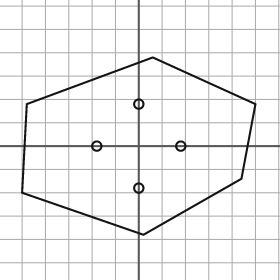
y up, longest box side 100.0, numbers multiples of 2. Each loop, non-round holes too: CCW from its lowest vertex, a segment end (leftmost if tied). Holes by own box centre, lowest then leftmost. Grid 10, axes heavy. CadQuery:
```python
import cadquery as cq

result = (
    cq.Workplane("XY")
    .moveTo(2.0, -38.0)
    .lineTo(44.0, -14.0)
    .lineTo(50.0, 18.0)
    .lineTo(6.0, 38.0)
    .lineTo(-48.0, 18.0)
    .lineTo(-50.0, -20.0)
    .close()
    .moveTo(0.0, -18.0)
    .circle(2.0)
    .moveTo(-18.0, 0.0)
    .circle(2.0)
    .moveTo(18.0, 0.0)
    .circle(2.0)
    .moveTo(0.0, 18.0)
    .circle(2.0)
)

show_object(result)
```